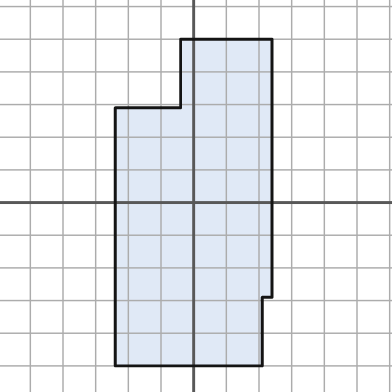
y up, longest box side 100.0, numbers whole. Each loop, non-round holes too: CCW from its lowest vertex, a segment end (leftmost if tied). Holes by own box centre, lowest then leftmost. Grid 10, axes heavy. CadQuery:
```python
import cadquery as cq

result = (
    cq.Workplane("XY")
    .moveTo(-24.0, -50.0)
    .lineTo(21.0, -50.0)
    .lineTo(21.0, -29.0)
    .lineTo(24.0, -29.0)
    .lineTo(24.0, 50.0)
    .lineTo(-4.0, 50.0)
    .lineTo(-4.0, 29.0)
    .lineTo(-24.0, 29.0)
    .close()
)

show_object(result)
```